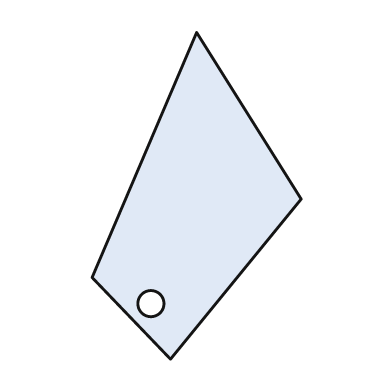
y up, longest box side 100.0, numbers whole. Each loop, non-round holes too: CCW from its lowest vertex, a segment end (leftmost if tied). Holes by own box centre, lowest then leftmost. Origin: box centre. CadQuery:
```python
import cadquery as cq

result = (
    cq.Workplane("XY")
    .moveTo(-8.0, -50.0)
    .lineTo(32.0, -1.0)
    .lineTo(0.0, 50.0)
    .lineTo(-32.0, -25.0)
    .close()
    .moveTo(-14.0, -33.0)
    .circle(4.0)
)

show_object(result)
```